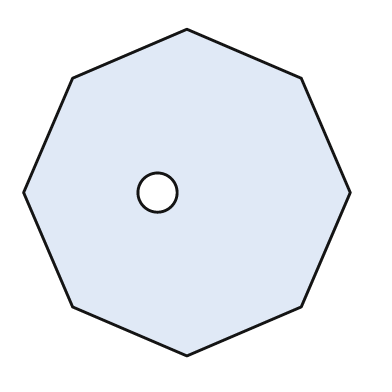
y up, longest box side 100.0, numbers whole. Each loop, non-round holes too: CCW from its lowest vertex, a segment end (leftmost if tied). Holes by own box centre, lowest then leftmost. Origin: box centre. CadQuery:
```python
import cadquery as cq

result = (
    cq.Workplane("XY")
    .moveTo(0.0, -50.0)
    .lineTo(35.0, -35.0)
    .lineTo(50.0, 0.0)
    .lineTo(35.0, 35.0)
    .lineTo(0.0, 50.0)
    .lineTo(-35.0, 35.0)
    .lineTo(-50.0, 0.0)
    .lineTo(-35.0, -35.0)
    .close()
    .moveTo(-9.0, 0.0)
    .circle(6.0)
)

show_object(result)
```